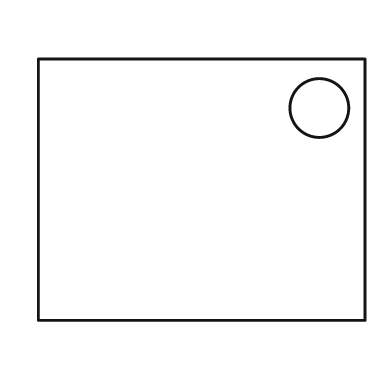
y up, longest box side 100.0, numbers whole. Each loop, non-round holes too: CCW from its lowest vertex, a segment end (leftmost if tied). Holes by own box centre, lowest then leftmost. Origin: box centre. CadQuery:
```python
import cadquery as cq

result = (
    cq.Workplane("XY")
    .moveTo(-50.0, -40.0)
    .lineTo(50.0, -40.0)
    .lineTo(50.0, 40.0)
    .lineTo(-50.0, 40.0)
    .close()
    .moveTo(36.0, 25.0)
    .circle(9.0)
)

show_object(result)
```